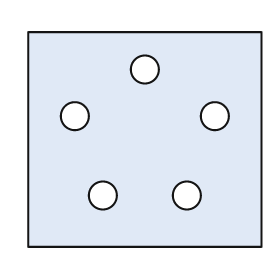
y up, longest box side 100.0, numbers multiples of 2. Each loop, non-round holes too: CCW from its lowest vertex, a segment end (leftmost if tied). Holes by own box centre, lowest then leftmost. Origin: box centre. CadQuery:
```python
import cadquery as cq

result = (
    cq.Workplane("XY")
    .moveTo(-50.0, -46.0)
    .lineTo(50.0, -46.0)
    .lineTo(50.0, 46.0)
    .lineTo(-50.0, 46.0)
    .close()
    .moveTo(-18.0, -24.0)
    .circle(6.0)
    .moveTo(18.0, -24.0)
    .circle(6.0)
    .moveTo(-30.0, 10.0)
    .circle(6.0)
    .moveTo(30.0, 10.0)
    .circle(6.0)
    .moveTo(0.0, 30.0)
    .circle(6.0)
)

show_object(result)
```